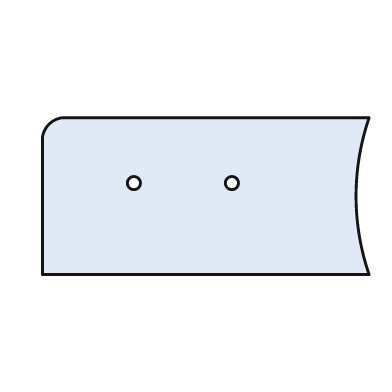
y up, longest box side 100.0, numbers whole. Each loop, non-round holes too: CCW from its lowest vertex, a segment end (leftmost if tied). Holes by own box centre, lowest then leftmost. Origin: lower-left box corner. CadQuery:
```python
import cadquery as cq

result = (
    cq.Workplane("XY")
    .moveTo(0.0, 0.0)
    .lineTo(100.0, 0.0)
    .threePointArc((96.0, 24.0), (100.0, 48.0))
    .lineTo(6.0, 48.0)
    .threePointArc((2.0, 46.0), (0.0, 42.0))
    .close()
    .moveTo(28.0, 28.0)
    .circle(2.0)
    .moveTo(58.0, 28.0)
    .circle(2.0)
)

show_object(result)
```